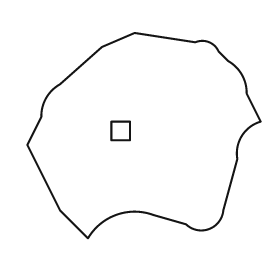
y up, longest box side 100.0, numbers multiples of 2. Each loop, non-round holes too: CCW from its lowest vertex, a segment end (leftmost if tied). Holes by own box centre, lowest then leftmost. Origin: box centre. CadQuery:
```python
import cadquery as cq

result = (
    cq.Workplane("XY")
    .moveTo(-24.0, -44.0)
    .threePointArc((-12.0, -34.0), (4.0, -34.0))
    .lineTo(18.0, -38.0)
    .threePointArc((28.0, -40.0), (34.0, -32.0))
    .lineTo(40.0, -10.0)
    .threePointArc((42.0, 0.0), (50.0, 6.0))
    .lineTo(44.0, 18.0)
    .threePointArc((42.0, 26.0), (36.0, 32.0))
    .lineTo(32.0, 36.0)
    .threePointArc((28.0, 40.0), (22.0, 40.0))
    .lineTo(-4.0, 44.0)
    .lineTo(-18.0, 38.0)
    .lineTo(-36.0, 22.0)
    .threePointArc((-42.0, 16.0), (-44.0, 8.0))
    .lineTo(-50.0, -4.0)
    .lineTo(-36.0, -32.0)
    .close()
    .moveTo(-14.0, -2.0)
    .lineTo(-6.0, -2.0)
    .lineTo(-6.0, 6.0)
    .lineTo(-14.0, 6.0)
    .close()
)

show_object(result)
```